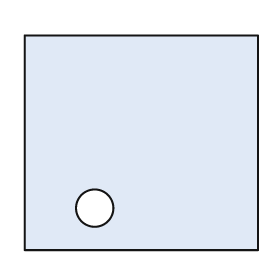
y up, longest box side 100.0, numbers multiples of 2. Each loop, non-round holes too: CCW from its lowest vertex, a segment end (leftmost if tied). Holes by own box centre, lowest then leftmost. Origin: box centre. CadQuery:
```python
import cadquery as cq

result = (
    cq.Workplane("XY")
    .moveTo(-50.0, -46.0)
    .lineTo(50.0, -46.0)
    .lineTo(50.0, 46.0)
    .lineTo(-50.0, 46.0)
    .close()
    .moveTo(-20.0, -28.0)
    .circle(8.0)
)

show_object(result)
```